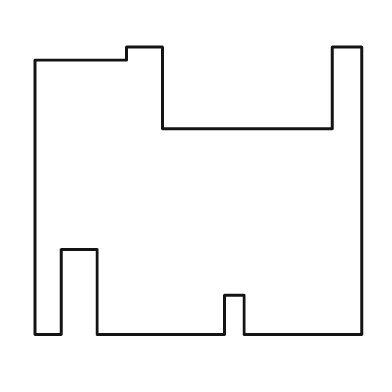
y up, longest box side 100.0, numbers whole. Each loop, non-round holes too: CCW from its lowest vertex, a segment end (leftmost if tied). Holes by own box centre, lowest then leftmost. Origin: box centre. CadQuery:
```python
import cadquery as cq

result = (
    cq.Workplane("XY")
    .moveTo(-50.0, -44.0)
    .lineTo(-42.0, -44.0)
    .lineTo(-42.0, -18.0)
    .lineTo(-31.0, -18.0)
    .lineTo(-31.0, -44.0)
    .lineTo(8.0, -44.0)
    .lineTo(8.0, -32.0)
    .lineTo(14.0, -32.0)
    .lineTo(14.0, -44.0)
    .lineTo(50.0, -44.0)
    .lineTo(50.0, 44.0)
    .lineTo(41.0, 44.0)
    .lineTo(41.0, 19.0)
    .lineTo(-11.0, 19.0)
    .lineTo(-11.0, 44.0)
    .lineTo(-22.0, 44.0)
    .lineTo(-22.0, 40.0)
    .lineTo(-50.0, 40.0)
    .close()
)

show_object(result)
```